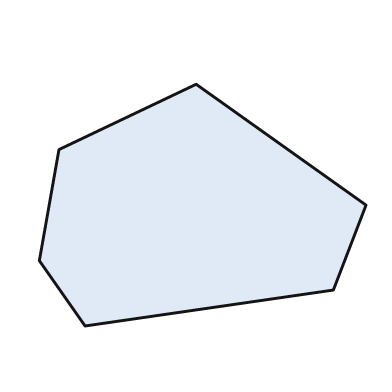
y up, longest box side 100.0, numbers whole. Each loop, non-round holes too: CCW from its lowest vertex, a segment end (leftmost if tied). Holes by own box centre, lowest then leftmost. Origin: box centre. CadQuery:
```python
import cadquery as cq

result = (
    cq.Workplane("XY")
    .moveTo(-36.0, -37.0)
    .lineTo(40.0, -26.0)
    .lineTo(50.0, 0.0)
    .lineTo(-2.0, 37.0)
    .lineTo(-44.0, 17.0)
    .lineTo(-50.0, -17.0)
    .close()
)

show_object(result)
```